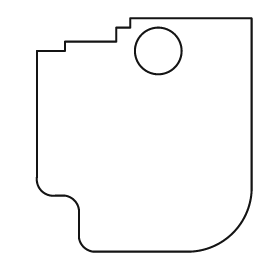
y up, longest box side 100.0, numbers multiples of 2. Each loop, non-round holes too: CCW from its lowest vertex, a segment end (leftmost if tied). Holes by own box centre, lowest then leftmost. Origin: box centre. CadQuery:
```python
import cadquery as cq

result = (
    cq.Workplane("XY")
    .moveTo(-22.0, -50.0)
    .lineTo(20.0, -50.0)
    .threePointArc((38.0, -42.0), (46.0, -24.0))
    .lineTo(46.0, 50.0)
    .lineTo(-6.0, 50.0)
    .lineTo(-6.0, 46.0)
    .lineTo(-12.0, 46.0)
    .lineTo(-12.0, 40.0)
    .lineTo(-34.0, 40.0)
    .lineTo(-34.0, 36.0)
    .lineTo(-46.0, 36.0)
    .lineTo(-46.0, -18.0)
    .threePointArc((-44.0, -24.0), (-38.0, -26.0))
    .lineTo(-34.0, -26.0)
    .threePointArc((-30.0, -28.0), (-28.0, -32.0))
    .lineTo(-28.0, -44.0)
    .threePointArc((-26.0, -48.0), (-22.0, -50.0))
    .close()
    .moveTo(6.0, 36.0)
    .circle(10.0)
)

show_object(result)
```